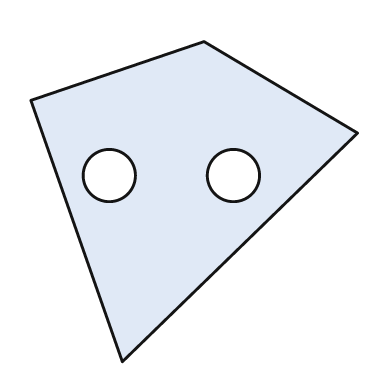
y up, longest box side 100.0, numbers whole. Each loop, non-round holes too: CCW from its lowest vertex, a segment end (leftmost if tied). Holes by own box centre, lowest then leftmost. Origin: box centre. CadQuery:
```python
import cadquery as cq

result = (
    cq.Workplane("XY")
    .moveTo(-22.0, -49.0)
    .lineTo(50.0, 21.0)
    .lineTo(3.0, 49.0)
    .lineTo(-50.0, 31.0)
    .close()
    .moveTo(-26.0, 8.0)
    .circle(8.0)
    .moveTo(12.0, 8.0)
    .circle(8.0)
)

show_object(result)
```